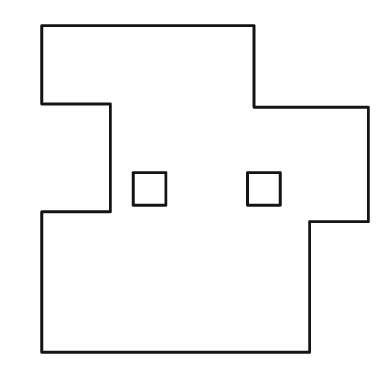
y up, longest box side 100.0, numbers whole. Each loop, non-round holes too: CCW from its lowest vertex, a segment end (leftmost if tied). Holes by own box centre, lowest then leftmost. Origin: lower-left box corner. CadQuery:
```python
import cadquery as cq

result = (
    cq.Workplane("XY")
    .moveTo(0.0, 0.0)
    .lineTo(82.0, 0.0)
    .lineTo(82.0, 40.0)
    .lineTo(100.0, 40.0)
    .lineTo(100.0, 75.0)
    .lineTo(65.0, 75.0)
    .lineTo(65.0, 100.0)
    .lineTo(0.0, 100.0)
    .lineTo(0.0, 76.0)
    .lineTo(21.0, 76.0)
    .lineTo(21.0, 43.0)
    .lineTo(0.0, 43.0)
    .close()
    .moveTo(28.0, 45.0)
    .lineTo(38.0, 45.0)
    .lineTo(38.0, 55.0)
    .lineTo(28.0, 55.0)
    .close()
    .moveTo(63.0, 45.0)
    .lineTo(73.0, 45.0)
    .lineTo(73.0, 55.0)
    .lineTo(63.0, 55.0)
    .close()
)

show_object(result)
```